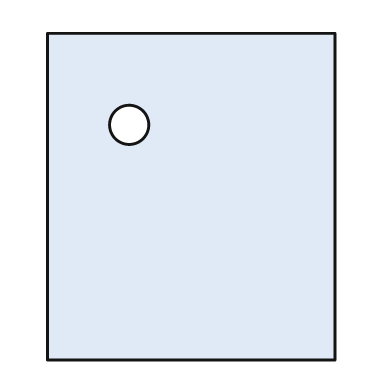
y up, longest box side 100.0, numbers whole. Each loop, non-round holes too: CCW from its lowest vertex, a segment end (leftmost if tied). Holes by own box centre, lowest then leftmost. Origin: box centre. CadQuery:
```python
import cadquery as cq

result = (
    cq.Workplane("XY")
    .moveTo(-44.0, -50.0)
    .lineTo(44.0, -50.0)
    .lineTo(44.0, 50.0)
    .lineTo(-44.0, 50.0)
    .close()
    .moveTo(-19.0, 22.0)
    .circle(6.0)
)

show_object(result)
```